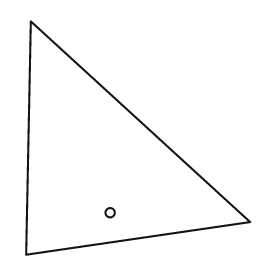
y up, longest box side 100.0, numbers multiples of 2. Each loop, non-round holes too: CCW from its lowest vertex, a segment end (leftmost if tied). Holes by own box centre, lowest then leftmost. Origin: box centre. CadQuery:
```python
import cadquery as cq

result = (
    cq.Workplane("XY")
    .moveTo(-48.0, -50.0)
    .lineTo(48.0, -36.0)
    .lineTo(-46.0, 50.0)
    .close()
    .moveTo(-12.0, -32.0)
    .circle(2.0)
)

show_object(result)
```